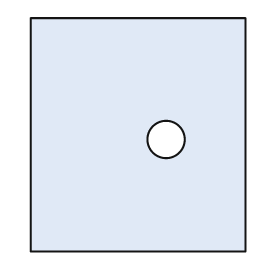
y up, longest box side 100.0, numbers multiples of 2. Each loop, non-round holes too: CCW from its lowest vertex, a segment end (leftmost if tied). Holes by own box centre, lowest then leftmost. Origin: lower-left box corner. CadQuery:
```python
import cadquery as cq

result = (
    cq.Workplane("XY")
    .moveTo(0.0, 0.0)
    .lineTo(92.0, 0.0)
    .lineTo(92.0, 100.0)
    .lineTo(0.0, 100.0)
    .close()
    .moveTo(58.0, 48.0)
    .circle(8.0)
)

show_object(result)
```